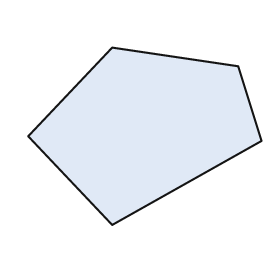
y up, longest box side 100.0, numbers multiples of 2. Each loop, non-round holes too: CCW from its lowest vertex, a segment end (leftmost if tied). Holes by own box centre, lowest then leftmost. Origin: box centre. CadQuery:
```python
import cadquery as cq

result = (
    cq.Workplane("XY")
    .moveTo(-14.0, -38.0)
    .lineTo(50.0, -2.0)
    .lineTo(40.0, 30.0)
    .lineTo(-14.0, 38.0)
    .lineTo(-50.0, 0.0)
    .close()
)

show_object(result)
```